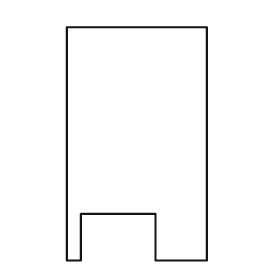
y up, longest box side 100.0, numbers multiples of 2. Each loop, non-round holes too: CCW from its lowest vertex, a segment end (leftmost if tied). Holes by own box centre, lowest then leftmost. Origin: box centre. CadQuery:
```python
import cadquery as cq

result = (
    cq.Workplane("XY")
    .moveTo(-30.0, -50.0)
    .lineTo(-24.0, -50.0)
    .lineTo(-24.0, -30.0)
    .lineTo(8.0, -30.0)
    .lineTo(8.0, -50.0)
    .lineTo(30.0, -50.0)
    .lineTo(30.0, 50.0)
    .lineTo(-30.0, 50.0)
    .close()
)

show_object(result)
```